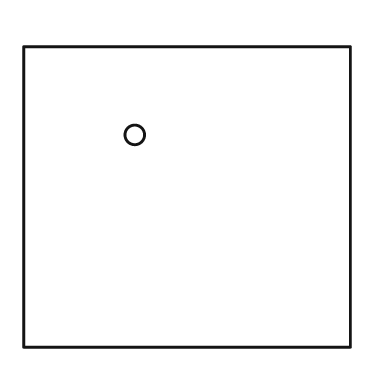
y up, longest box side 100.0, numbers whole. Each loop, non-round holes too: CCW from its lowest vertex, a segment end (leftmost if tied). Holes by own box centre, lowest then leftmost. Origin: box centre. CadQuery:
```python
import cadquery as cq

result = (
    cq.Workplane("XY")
    .moveTo(-50.0, -46.0)
    .lineTo(50.0, -46.0)
    .lineTo(50.0, 46.0)
    .lineTo(-50.0, 46.0)
    .close()
    .moveTo(-16.0, 19.0)
    .circle(3.0)
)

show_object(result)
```